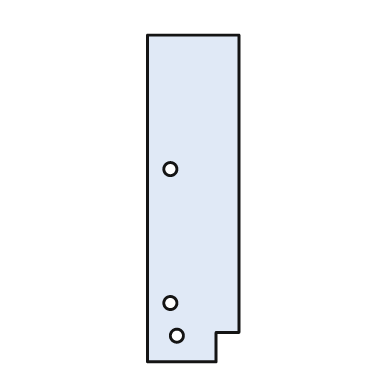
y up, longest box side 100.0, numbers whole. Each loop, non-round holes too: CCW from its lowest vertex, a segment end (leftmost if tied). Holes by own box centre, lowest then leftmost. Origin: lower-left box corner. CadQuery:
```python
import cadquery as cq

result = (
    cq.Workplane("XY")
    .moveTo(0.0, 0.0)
    .lineTo(21.0, 0.0)
    .lineTo(21.0, 9.0)
    .lineTo(28.0, 9.0)
    .lineTo(28.0, 100.0)
    .lineTo(0.0, 100.0)
    .close()
    .moveTo(9.0, 8.0)
    .circle(2.0)
    .moveTo(7.0, 18.0)
    .circle(2.0)
    .moveTo(7.0, 59.0)
    .circle(2.0)
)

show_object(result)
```